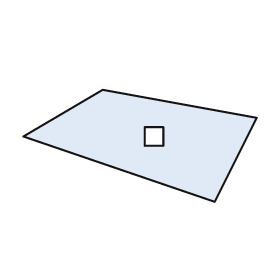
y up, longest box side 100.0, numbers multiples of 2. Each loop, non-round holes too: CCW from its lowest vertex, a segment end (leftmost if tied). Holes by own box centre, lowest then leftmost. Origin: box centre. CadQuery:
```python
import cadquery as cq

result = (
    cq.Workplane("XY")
    .moveTo(32.0, -24.0)
    .lineTo(50.0, 12.0)
    .lineTo(-16.0, 24.0)
    .lineTo(-50.0, 4.0)
    .close()
    .moveTo(2.0, 0.0)
    .lineTo(10.0, 0.0)
    .lineTo(10.0, 8.0)
    .lineTo(2.0, 8.0)
    .close()
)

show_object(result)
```